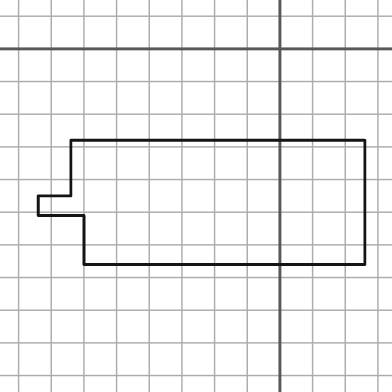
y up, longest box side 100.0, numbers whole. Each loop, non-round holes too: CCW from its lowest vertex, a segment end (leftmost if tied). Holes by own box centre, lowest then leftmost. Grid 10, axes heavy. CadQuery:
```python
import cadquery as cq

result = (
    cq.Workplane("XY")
    .moveTo(-60.0, -66.0)
    .lineTo(26.0, -66.0)
    .lineTo(26.0, -28.0)
    .lineTo(-64.0, -28.0)
    .lineTo(-64.0, -45.0)
    .lineTo(-74.0, -45.0)
    .lineTo(-74.0, -51.0)
    .lineTo(-60.0, -51.0)
    .close()
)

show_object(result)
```